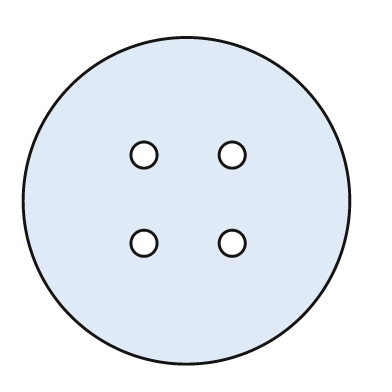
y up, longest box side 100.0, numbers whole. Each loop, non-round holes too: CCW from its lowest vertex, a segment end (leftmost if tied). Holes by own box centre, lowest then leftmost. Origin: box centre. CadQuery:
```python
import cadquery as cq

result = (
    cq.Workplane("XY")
    .moveTo(0.0, 0.0)
    .circle(50.0)
    .moveTo(-13.0, -13.0)
    .circle(4.0)
    .moveTo(14.0, -13.0)
    .circle(4.0)
    .moveTo(-13.0, 14.0)
    .circle(4.0)
    .moveTo(14.0, 14.0)
    .circle(4.0)
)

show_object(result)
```